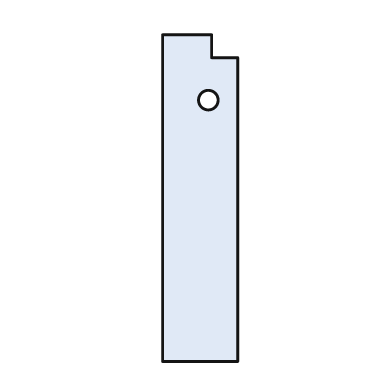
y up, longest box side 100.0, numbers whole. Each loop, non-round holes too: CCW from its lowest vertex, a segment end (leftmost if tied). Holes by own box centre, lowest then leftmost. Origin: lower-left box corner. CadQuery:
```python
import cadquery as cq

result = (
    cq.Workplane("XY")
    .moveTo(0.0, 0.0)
    .lineTo(23.0, 0.0)
    .lineTo(23.0, 93.0)
    .lineTo(15.0, 93.0)
    .lineTo(15.0, 100.0)
    .lineTo(0.0, 100.0)
    .close()
    .moveTo(14.0, 80.0)
    .circle(3.0)
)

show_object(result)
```